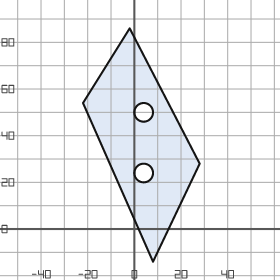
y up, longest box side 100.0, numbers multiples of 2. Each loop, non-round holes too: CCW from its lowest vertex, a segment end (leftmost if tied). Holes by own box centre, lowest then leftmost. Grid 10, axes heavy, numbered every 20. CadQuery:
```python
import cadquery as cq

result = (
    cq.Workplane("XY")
    .moveTo(8.0, -14.0)
    .lineTo(28.0, 28.0)
    .lineTo(-2.0, 86.0)
    .lineTo(-22.0, 54.0)
    .close()
    .moveTo(4.0, 24.0)
    .circle(4.0)
    .moveTo(4.0, 50.0)
    .circle(4.0)
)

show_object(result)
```